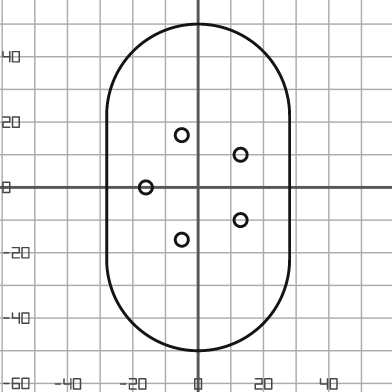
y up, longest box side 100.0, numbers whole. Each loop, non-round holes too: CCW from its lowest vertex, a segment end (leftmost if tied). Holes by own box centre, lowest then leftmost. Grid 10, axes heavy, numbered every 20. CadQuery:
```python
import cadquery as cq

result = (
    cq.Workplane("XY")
    .moveTo(-28.0, -22.0)
    .threePointArc((0.0, -50.0), (28.0, -22.0))
    .lineTo(28.0, 22.0)
    .threePointArc((0.0, 50.0), (-28.0, 22.0))
    .close()
    .moveTo(-5.0, -16.0)
    .circle(2.0)
    .moveTo(13.0, -10.0)
    .circle(2.0)
    .moveTo(-16.0, 0.0)
    .circle(2.0)
    .moveTo(13.0, 10.0)
    .circle(2.0)
    .moveTo(-5.0, 16.0)
    .circle(2.0)
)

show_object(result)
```